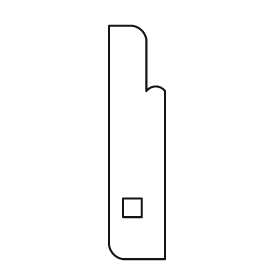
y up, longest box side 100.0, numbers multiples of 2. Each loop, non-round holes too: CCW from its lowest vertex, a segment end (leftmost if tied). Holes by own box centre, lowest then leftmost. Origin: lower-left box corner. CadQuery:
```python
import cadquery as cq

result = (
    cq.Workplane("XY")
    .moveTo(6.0, 0.0)
    .lineTo(24.0, 0.0)
    .lineTo(24.0, 72.0)
    .threePointArc((20.0, 74.0), (16.0, 72.0))
    .lineTo(16.0, 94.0)
    .threePointArc((14.0, 98.0), (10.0, 100.0))
    .lineTo(0.0, 100.0)
    .lineTo(0.0, 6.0)
    .threePointArc((2.0, 2.0), (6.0, 0.0))
    .close()
    .moveTo(6.0, 18.0)
    .lineTo(14.0, 18.0)
    .lineTo(14.0, 26.0)
    .lineTo(6.0, 26.0)
    .close()
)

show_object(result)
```